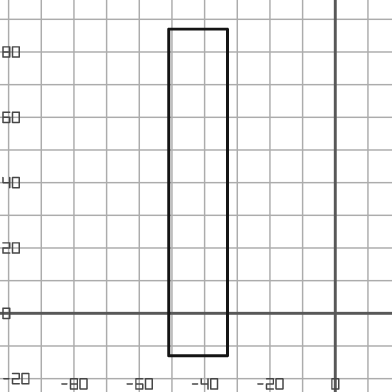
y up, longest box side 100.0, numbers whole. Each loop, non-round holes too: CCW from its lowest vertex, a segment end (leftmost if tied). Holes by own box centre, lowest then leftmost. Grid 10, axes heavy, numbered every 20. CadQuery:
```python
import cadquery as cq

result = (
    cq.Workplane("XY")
    .moveTo(-51.0, -13.0)
    .lineTo(-33.0, -13.0)
    .lineTo(-33.0, 87.0)
    .lineTo(-51.0, 87.0)
    .close()
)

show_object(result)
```